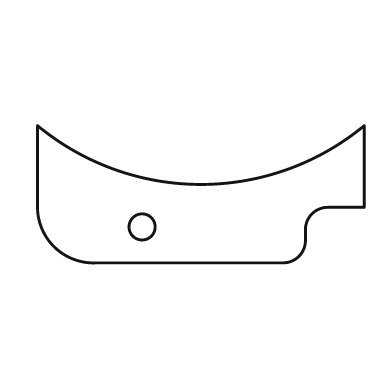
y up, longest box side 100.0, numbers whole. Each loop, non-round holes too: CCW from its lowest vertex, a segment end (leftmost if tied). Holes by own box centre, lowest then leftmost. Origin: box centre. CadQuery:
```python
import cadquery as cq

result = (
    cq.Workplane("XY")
    .moveTo(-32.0, -21.0)
    .lineTo(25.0, -21.0)
    .threePointArc((30.0, -19.0), (32.0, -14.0))
    .lineTo(32.0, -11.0)
    .threePointArc((34.0, -6.0), (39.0, -4.0))
    .lineTo(50.0, -4.0)
    .lineTo(50.0, 21.0)
    .threePointArc((0.0, 3.0), (-50.0, 21.0))
    .lineTo(-50.0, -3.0)
    .threePointArc((-45.0, -16.0), (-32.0, -21.0))
    .close()
    .moveTo(-18.0, -10.0)
    .circle(4.0)
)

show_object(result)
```